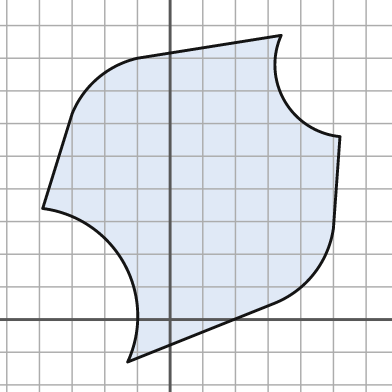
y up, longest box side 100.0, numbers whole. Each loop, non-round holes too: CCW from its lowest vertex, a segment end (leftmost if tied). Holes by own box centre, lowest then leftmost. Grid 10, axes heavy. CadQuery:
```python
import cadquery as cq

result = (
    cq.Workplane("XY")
    .moveTo(-13.0, -13.0)
    .lineTo(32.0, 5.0)
    .threePointArc((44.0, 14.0), (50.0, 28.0))
    .lineTo(52.0, 56.0)
    .threePointArc((35.0, 67.0), (34.0, 87.0))
    .lineTo(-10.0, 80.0)
    .threePointArc((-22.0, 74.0), (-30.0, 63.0))
    .lineTo(-39.0, 34.0)
    .threePointArc((-14.0, 17.0), (-13.0, -13.0))
    .close()
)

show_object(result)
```